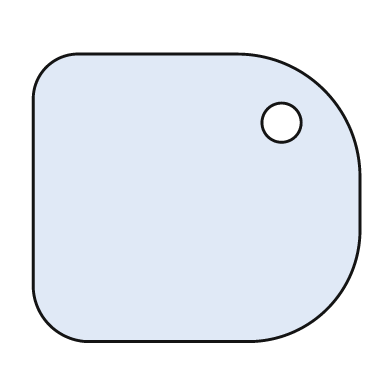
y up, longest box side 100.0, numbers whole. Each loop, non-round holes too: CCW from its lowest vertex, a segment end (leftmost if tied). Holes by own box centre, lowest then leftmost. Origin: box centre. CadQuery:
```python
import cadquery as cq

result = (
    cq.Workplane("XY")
    .moveTo(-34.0, -44.0)
    .lineTo(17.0, -44.0)
    .threePointArc((40.0, -34.0), (50.0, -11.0))
    .lineTo(50.0, 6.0)
    .threePointArc((39.0, 33.0), (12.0, 44.0))
    .lineTo(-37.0, 44.0)
    .threePointArc((-46.0, 40.0), (-50.0, 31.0))
    .lineTo(-50.0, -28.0)
    .threePointArc((-45.0, -39.0), (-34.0, -44.0))
    .close()
    .moveTo(26.0, 23.0)
    .circle(6.0)
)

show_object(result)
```